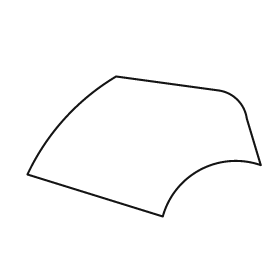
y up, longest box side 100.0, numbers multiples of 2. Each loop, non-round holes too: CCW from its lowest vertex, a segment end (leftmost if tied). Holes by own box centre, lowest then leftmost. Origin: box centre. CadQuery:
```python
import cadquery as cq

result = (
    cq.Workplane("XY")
    .moveTo(8.0, -30.0)
    .threePointArc((24.0, -10.0), (50.0, -8.0))
    .lineTo(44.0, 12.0)
    .threePointArc((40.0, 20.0), (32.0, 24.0))
    .lineTo(-12.0, 30.0)
    .threePointArc((-34.0, 12.0), (-50.0, -12.0))
    .close()
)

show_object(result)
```